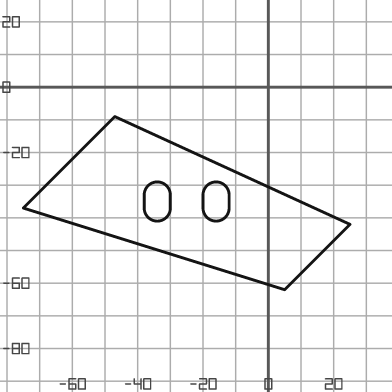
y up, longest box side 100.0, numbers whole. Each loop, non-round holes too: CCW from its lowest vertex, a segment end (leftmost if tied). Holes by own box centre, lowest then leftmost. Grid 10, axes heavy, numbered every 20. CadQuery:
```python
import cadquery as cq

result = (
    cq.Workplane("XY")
    .moveTo(5.0, -62.0)
    .lineTo(25.0, -42.0)
    .lineTo(-47.0, -9.0)
    .lineTo(-75.0, -37.0)
    .close()
    .moveTo(-38.0, -37.0)
    .threePointArc((-34.0, -41.0), (-30.0, -37.0))
    .lineTo(-30.0, -33.0)
    .threePointArc((-34.0, -29.0), (-38.0, -33.0))
    .close()
    .moveTo(-20.0, -37.0)
    .threePointArc((-16.0, -41.0), (-12.0, -37.0))
    .lineTo(-12.0, -33.0)
    .threePointArc((-16.0, -29.0), (-20.0, -33.0))
    .close()
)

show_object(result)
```